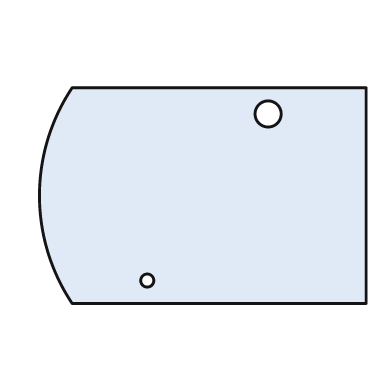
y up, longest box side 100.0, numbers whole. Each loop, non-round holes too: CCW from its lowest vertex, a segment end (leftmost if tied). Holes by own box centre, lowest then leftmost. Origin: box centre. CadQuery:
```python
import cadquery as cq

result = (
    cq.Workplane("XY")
    .moveTo(-40.0, -33.0)
    .lineTo(50.0, -33.0)
    .lineTo(50.0, 33.0)
    .lineTo(-40.0, 33.0)
    .threePointArc((-50.0, 0.0), (-40.0, -33.0))
    .close()
    .moveTo(-17.0, -26.0)
    .circle(2.0)
    .moveTo(20.0, 25.0)
    .circle(4.0)
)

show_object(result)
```